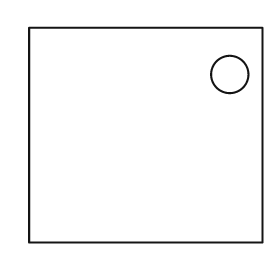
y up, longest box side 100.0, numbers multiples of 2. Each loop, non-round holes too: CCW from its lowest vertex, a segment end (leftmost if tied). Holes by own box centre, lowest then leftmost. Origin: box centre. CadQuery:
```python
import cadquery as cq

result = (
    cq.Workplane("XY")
    .moveTo(-50.0, -46.0)
    .lineTo(50.0, -46.0)
    .lineTo(50.0, 46.0)
    .lineTo(-50.0, 46.0)
    .close()
    .moveTo(36.0, 26.0)
    .circle(8.0)
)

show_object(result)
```